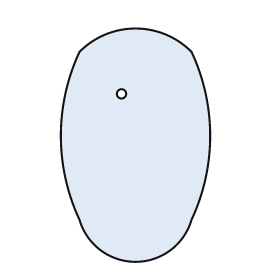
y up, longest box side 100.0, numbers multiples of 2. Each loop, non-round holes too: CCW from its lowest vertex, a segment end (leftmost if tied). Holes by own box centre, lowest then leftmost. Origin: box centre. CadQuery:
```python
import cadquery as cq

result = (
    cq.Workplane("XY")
    .moveTo(-24.0, -32.0)
    .threePointArc((0.0, -50.0), (24.0, -32.0))
    .threePointArc((32.0, 4.0), (24.0, 40.0))
    .threePointArc((0.0, 50.0), (-24.0, 40.0))
    .threePointArc((-32.0, 4.0), (-24.0, -32.0))
    .close()
    .moveTo(-6.0, 22.0)
    .circle(2.0)
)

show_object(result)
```